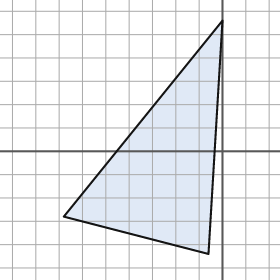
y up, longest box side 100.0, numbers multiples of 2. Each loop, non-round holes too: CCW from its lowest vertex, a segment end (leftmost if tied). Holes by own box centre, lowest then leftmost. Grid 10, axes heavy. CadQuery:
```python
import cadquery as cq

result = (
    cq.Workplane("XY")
    .moveTo(-6.0, -44.0)
    .lineTo(0.0, 56.0)
    .lineTo(-68.0, -28.0)
    .close()
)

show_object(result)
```